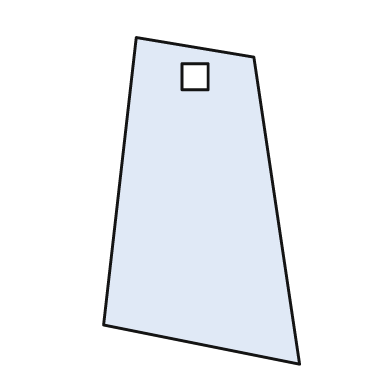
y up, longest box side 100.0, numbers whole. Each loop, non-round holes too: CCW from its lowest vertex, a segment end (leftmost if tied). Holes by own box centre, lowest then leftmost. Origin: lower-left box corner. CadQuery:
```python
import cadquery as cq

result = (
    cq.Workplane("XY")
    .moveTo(60.0, 0.0)
    .lineTo(46.0, 94.0)
    .lineTo(10.0, 100.0)
    .lineTo(0.0, 12.0)
    .close()
    .moveTo(24.0, 84.0)
    .lineTo(32.0, 84.0)
    .lineTo(32.0, 92.0)
    .lineTo(24.0, 92.0)
    .close()
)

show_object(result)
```